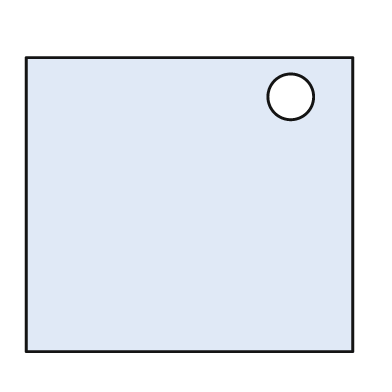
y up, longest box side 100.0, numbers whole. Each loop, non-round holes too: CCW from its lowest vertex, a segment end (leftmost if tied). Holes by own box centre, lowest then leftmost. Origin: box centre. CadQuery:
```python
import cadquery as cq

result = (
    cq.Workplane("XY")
    .moveTo(-50.0, -45.0)
    .lineTo(50.0, -45.0)
    .lineTo(50.0, 45.0)
    .lineTo(-50.0, 45.0)
    .close()
    .moveTo(31.0, 33.0)
    .circle(7.0)
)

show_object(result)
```